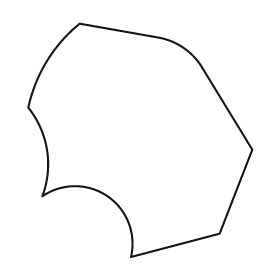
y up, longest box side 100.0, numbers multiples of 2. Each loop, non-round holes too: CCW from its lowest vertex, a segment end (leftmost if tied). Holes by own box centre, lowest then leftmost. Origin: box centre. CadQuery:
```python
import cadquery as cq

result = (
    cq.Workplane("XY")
    .moveTo(-4.0, -50.0)
    .lineTo(34.0, -40.0)
    .lineTo(48.0, -4.0)
    .lineTo(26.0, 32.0)
    .threePointArc((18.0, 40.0), (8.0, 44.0))
    .lineTo(-26.0, 50.0)
    .threePointArc((-40.0, 34.0), (-48.0, 14.0))
    .threePointArc((-40.0, -4.0), (-42.0, -24.0))
    .threePointArc((-14.0, -24.0), (-4.0, -50.0))
    .close()
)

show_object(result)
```